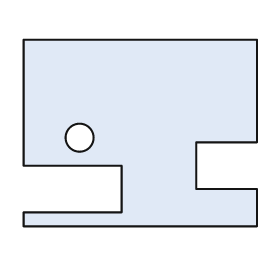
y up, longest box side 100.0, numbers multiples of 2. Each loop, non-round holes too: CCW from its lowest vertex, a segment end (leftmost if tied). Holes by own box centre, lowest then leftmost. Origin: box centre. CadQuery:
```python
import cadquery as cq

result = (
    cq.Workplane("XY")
    .moveTo(-50.0, -40.0)
    .lineTo(50.0, -40.0)
    .lineTo(50.0, -24.0)
    .lineTo(24.0, -24.0)
    .lineTo(24.0, -4.0)
    .lineTo(50.0, -4.0)
    .lineTo(50.0, 40.0)
    .lineTo(-50.0, 40.0)
    .lineTo(-50.0, -14.0)
    .lineTo(-8.0, -14.0)
    .lineTo(-8.0, -34.0)
    .lineTo(-50.0, -34.0)
    .close()
    .moveTo(-26.0, -2.0)
    .circle(6.0)
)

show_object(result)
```